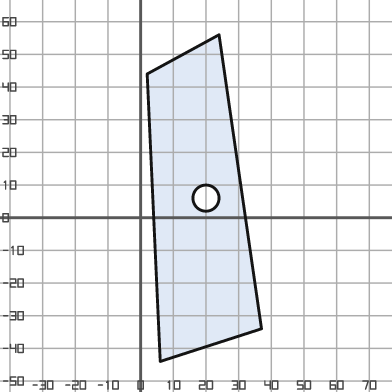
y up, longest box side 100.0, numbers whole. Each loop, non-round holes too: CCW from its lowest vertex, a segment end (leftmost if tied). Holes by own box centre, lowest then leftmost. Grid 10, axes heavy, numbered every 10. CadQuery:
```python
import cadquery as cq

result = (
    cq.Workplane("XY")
    .moveTo(6.0, -44.0)
    .lineTo(37.0, -34.0)
    .lineTo(24.0, 56.0)
    .lineTo(2.0, 44.0)
    .close()
    .moveTo(20.0, 6.0)
    .circle(4.0)
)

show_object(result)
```